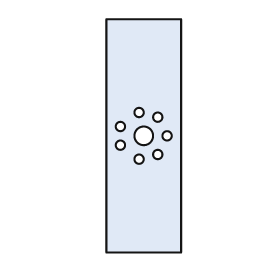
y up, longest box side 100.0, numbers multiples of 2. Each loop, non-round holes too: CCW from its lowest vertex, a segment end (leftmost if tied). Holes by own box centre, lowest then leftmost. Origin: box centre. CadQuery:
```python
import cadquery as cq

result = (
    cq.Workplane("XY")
    .moveTo(-16.0, -50.0)
    .lineTo(16.0, -50.0)
    .lineTo(16.0, 50.0)
    .lineTo(-16.0, 50.0)
    .close()
    .moveTo(-2.0, -10.0)
    .circle(2.0)
    .moveTo(6.0, -8.0)
    .circle(2.0)
    .moveTo(-10.0, -4.0)
    .circle(2.0)
    .moveTo(0.0, 0.0)
    .circle(4.0)
    .moveTo(10.0, 0.0)
    .circle(2.0)
    .moveTo(-10.0, 4.0)
    .circle(2.0)
    .moveTo(6.0, 8.0)
    .circle(2.0)
    .moveTo(-2.0, 10.0)
    .circle(2.0)
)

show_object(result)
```